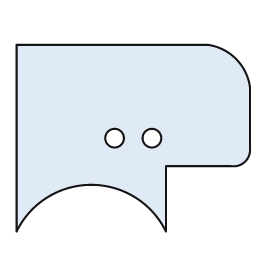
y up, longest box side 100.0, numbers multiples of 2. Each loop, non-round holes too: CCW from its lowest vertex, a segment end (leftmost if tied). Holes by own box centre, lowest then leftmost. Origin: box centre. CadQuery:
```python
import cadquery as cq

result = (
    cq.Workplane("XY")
    .moveTo(-50.0, -40.0)
    .threePointArc((-18.0, -20.0), (14.0, -40.0))
    .lineTo(14.0, -12.0)
    .lineTo(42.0, -12.0)
    .threePointArc((48.0, -10.0), (50.0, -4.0))
    .lineTo(50.0, 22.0)
    .threePointArc((44.0, 34.0), (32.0, 40.0))
    .lineTo(-50.0, 40.0)
    .close()
    .moveTo(-8.0, 0.0)
    .circle(4.0)
    .moveTo(8.0, 0.0)
    .circle(4.0)
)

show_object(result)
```